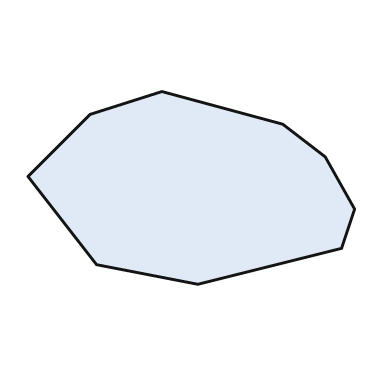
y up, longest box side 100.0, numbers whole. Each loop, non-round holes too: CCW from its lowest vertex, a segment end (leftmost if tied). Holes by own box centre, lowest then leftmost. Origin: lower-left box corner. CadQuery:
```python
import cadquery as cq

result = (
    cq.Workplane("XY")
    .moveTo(52.0, 0.0)
    .lineTo(96.0, 11.0)
    .lineTo(100.0, 23.0)
    .lineTo(91.0, 39.0)
    .lineTo(78.0, 49.0)
    .lineTo(41.0, 59.0)
    .lineTo(19.0, 52.0)
    .lineTo(0.0, 33.0)
    .lineTo(21.0, 6.0)
    .close()
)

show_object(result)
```